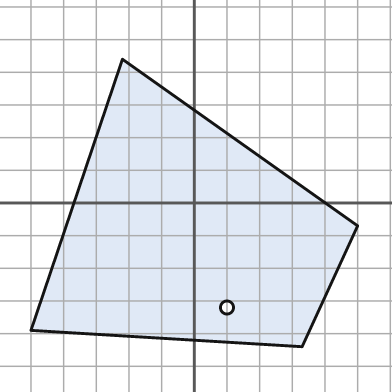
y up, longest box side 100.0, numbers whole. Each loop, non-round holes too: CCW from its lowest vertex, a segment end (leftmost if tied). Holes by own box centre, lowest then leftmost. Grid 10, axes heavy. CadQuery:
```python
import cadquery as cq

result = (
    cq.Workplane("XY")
    .moveTo(33.0, -44.0)
    .lineTo(50.0, -7.0)
    .lineTo(-22.0, 44.0)
    .lineTo(-50.0, -39.0)
    .close()
    .moveTo(10.0, -32.0)
    .circle(2.0)
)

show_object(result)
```